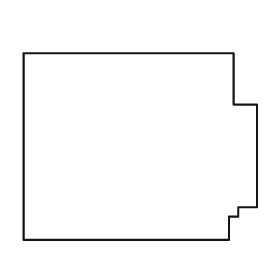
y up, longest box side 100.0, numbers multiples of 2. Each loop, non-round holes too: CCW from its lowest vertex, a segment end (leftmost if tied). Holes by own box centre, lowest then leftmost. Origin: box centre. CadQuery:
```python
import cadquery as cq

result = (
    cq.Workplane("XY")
    .moveTo(-50.0, -40.0)
    .lineTo(38.0, -40.0)
    .lineTo(38.0, -30.0)
    .lineTo(42.0, -30.0)
    .lineTo(42.0, -26.0)
    .lineTo(50.0, -26.0)
    .lineTo(50.0, 18.0)
    .lineTo(40.0, 18.0)
    .lineTo(40.0, 40.0)
    .lineTo(-50.0, 40.0)
    .close()
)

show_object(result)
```